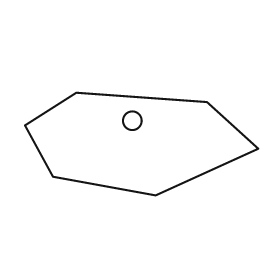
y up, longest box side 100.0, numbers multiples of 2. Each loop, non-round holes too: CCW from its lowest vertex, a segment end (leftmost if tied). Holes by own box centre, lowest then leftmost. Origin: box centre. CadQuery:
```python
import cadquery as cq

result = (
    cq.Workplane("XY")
    .moveTo(6.0, -22.0)
    .lineTo(50.0, -2.0)
    .lineTo(28.0, 18.0)
    .lineTo(-28.0, 22.0)
    .lineTo(-50.0, 8.0)
    .lineTo(-38.0, -14.0)
    .close()
    .moveTo(-4.0, 10.0)
    .circle(4.0)
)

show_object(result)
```